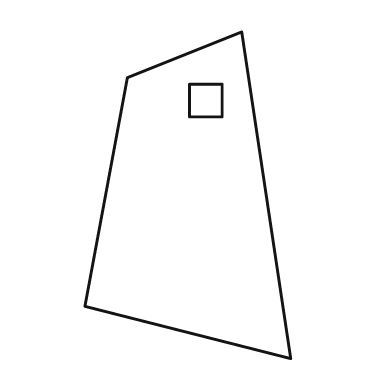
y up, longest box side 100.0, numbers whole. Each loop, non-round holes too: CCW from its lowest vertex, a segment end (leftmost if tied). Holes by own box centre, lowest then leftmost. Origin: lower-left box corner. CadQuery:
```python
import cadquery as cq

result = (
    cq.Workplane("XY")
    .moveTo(63.0, 0.0)
    .lineTo(48.0, 100.0)
    .lineTo(13.0, 86.0)
    .lineTo(0.0, 16.0)
    .close()
    .moveTo(32.0, 74.0)
    .lineTo(42.0, 74.0)
    .lineTo(42.0, 84.0)
    .lineTo(32.0, 84.0)
    .close()
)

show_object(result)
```